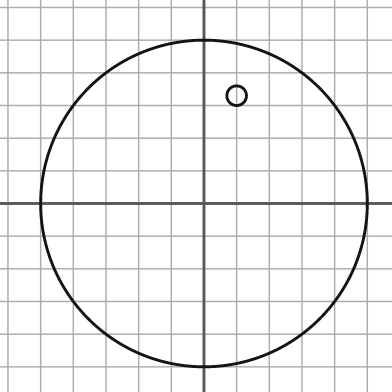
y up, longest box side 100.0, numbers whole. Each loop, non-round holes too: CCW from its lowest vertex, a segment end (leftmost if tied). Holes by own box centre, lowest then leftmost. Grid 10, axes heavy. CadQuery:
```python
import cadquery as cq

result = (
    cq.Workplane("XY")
    .moveTo(0.0, 0.0)
    .circle(50.0)
    .moveTo(10.0, 33.0)
    .circle(3.0)
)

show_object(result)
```